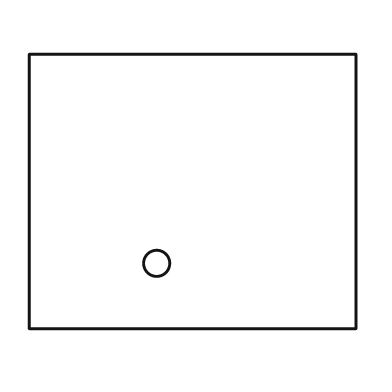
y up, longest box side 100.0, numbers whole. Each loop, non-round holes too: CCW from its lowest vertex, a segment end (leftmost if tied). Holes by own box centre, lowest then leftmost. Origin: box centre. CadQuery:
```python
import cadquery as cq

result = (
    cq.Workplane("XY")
    .moveTo(-50.0, -42.0)
    .lineTo(50.0, -42.0)
    .lineTo(50.0, 42.0)
    .lineTo(-50.0, 42.0)
    .close()
    .moveTo(-11.0, -22.0)
    .circle(4.0)
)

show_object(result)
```